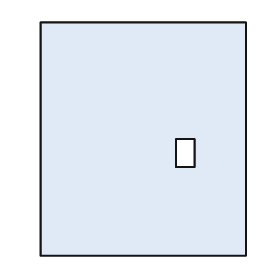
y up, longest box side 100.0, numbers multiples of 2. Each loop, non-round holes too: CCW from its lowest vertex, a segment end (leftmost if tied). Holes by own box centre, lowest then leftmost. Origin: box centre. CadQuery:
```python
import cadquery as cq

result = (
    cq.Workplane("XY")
    .moveTo(-44.0, -50.0)
    .lineTo(44.0, -50.0)
    .lineTo(44.0, 50.0)
    .lineTo(-44.0, 50.0)
    .close()
    .moveTo(14.0, -12.0)
    .lineTo(22.0, -12.0)
    .lineTo(22.0, 0.0)
    .lineTo(14.0, 0.0)
    .close()
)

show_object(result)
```